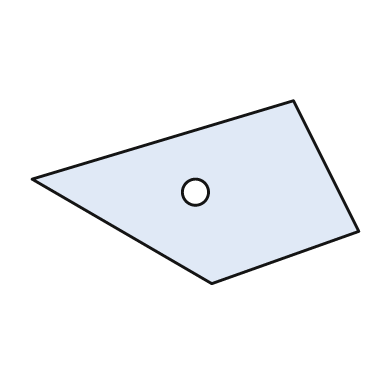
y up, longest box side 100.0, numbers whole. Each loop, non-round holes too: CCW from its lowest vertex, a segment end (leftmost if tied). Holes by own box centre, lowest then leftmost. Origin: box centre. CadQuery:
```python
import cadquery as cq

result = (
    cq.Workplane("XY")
    .moveTo(5.0, -28.0)
    .lineTo(50.0, -12.0)
    .lineTo(30.0, 28.0)
    .lineTo(-50.0, 4.0)
    .close()
    .moveTo(0.0, 0.0)
    .circle(4.0)
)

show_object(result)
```